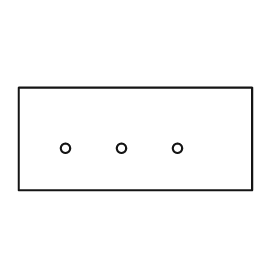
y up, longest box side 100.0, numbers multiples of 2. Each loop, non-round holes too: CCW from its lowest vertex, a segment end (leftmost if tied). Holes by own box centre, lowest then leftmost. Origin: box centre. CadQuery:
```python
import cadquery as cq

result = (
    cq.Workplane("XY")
    .moveTo(-50.0, -22.0)
    .lineTo(50.0, -22.0)
    .lineTo(50.0, 22.0)
    .lineTo(-50.0, 22.0)
    .close()
    .moveTo(-30.0, -4.0)
    .circle(2.0)
    .moveTo(-6.0, -4.0)
    .circle(2.0)
    .moveTo(18.0, -4.0)
    .circle(2.0)
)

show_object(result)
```